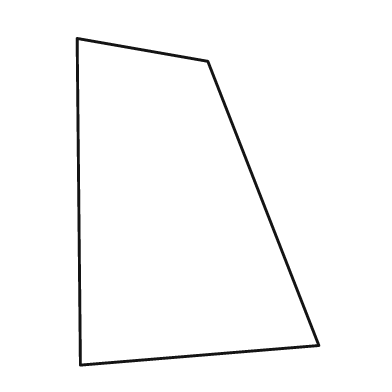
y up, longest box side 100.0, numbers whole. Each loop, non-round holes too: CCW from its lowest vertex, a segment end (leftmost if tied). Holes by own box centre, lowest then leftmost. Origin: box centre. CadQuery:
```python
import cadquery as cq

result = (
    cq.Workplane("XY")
    .moveTo(-36.0, -50.0)
    .lineTo(37.0, -44.0)
    .lineTo(3.0, 43.0)
    .lineTo(-37.0, 50.0)
    .close()
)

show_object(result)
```